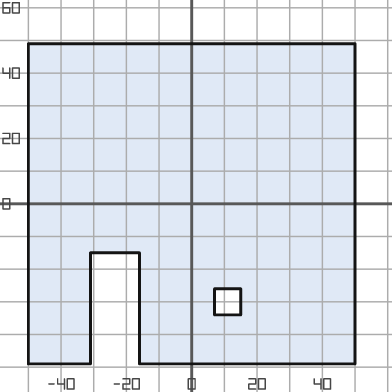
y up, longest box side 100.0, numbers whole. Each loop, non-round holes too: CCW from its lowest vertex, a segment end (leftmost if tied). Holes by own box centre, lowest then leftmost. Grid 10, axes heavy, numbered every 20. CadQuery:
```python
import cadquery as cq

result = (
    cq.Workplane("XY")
    .moveTo(-50.0, -49.0)
    .lineTo(-31.0, -49.0)
    .lineTo(-31.0, -15.0)
    .lineTo(-16.0, -15.0)
    .lineTo(-16.0, -49.0)
    .lineTo(50.0, -49.0)
    .lineTo(50.0, 49.0)
    .lineTo(-50.0, 49.0)
    .close()
    .moveTo(7.0, -34.0)
    .lineTo(15.0, -34.0)
    .lineTo(15.0, -26.0)
    .lineTo(7.0, -26.0)
    .close()
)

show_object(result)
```